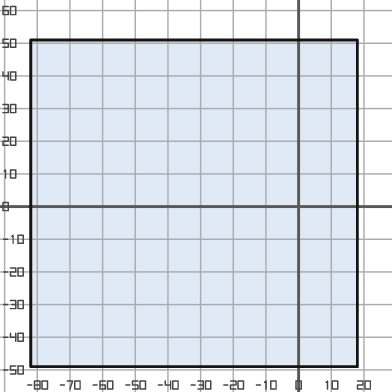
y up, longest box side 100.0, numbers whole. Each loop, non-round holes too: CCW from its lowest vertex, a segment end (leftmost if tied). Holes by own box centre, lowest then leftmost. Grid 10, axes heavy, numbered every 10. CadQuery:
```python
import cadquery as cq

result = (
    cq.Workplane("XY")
    .moveTo(-82.0, -49.0)
    .lineTo(18.0, -49.0)
    .lineTo(18.0, 51.0)
    .lineTo(-82.0, 51.0)
    .close()
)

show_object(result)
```